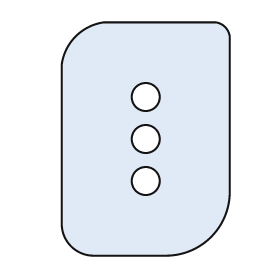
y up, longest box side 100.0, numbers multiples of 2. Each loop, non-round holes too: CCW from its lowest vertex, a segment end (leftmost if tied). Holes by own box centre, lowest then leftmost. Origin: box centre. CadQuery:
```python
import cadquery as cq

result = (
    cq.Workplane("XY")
    .moveTo(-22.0, -50.0)
    .lineTo(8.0, -50.0)
    .threePointArc((28.0, -42.0), (36.0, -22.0))
    .lineTo(36.0, 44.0)
    .threePointArc((34.0, 48.0), (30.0, 50.0))
    .lineTo(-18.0, 50.0)
    .threePointArc((-30.0, 44.0), (-36.0, 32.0))
    .lineTo(-36.0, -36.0)
    .threePointArc((-32.0, -46.0), (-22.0, -50.0))
    .close()
    .moveTo(0.0, -18.0)
    .circle(6.0)
    .moveTo(0.0, 0.0)
    .circle(6.0)
    .moveTo(0.0, 18.0)
    .circle(6.0)
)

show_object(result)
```